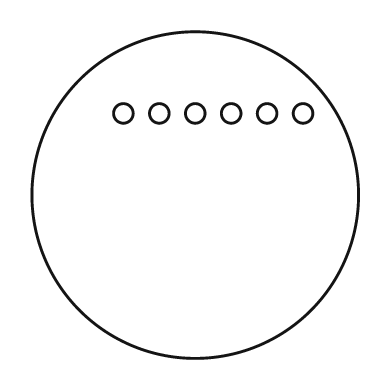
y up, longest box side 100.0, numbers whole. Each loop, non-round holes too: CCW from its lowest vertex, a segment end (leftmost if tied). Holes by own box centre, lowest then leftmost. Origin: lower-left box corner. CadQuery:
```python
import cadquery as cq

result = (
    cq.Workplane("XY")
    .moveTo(50.0, 50.0)
    .circle(50.0)
    .moveTo(28.0, 75.0)
    .circle(3.0)
    .moveTo(39.0, 75.0)
    .circle(3.0)
    .moveTo(50.0, 75.0)
    .circle(3.0)
    .moveTo(61.0, 75.0)
    .circle(3.0)
    .moveTo(72.0, 75.0)
    .circle(3.0)
    .moveTo(83.0, 75.0)
    .circle(3.0)
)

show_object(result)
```